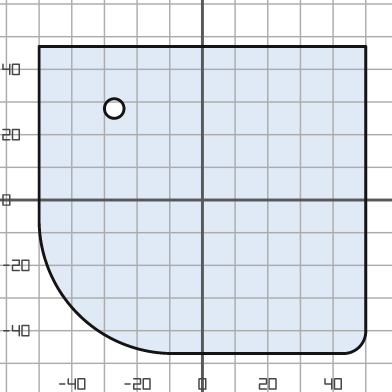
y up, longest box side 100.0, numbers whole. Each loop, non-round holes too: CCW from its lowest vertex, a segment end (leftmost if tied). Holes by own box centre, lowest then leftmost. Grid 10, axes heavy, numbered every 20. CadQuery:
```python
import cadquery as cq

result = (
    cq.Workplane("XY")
    .moveTo(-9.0, -47.0)
    .lineTo(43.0, -47.0)
    .threePointArc((48.0, -45.0), (50.0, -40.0))
    .lineTo(50.0, 47.0)
    .lineTo(-50.0, 47.0)
    .lineTo(-50.0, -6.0)
    .threePointArc((-38.0, -35.0), (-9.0, -47.0))
    .close()
    .moveTo(-27.0, 28.0)
    .circle(3.0)
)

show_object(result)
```